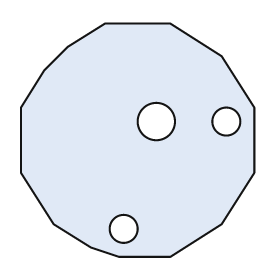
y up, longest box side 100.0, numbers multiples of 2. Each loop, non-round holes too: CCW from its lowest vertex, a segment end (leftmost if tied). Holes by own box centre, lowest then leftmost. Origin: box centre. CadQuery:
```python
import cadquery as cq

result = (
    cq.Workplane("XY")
    .moveTo(-8.0, -50.0)
    .lineTo(14.0, -50.0)
    .lineTo(36.0, -36.0)
    .lineTo(50.0, -14.0)
    .lineTo(50.0, 14.0)
    .lineTo(36.0, 36.0)
    .lineTo(14.0, 50.0)
    .lineTo(-14.0, 50.0)
    .lineTo(-30.0, 40.0)
    .lineTo(-40.0, 30.0)
    .lineTo(-50.0, 14.0)
    .lineTo(-50.0, -14.0)
    .lineTo(-36.0, -36.0)
    .lineTo(-20.0, -46.0)
    .close()
    .moveTo(-6.0, -38.0)
    .circle(6.0)
    .moveTo(8.0, 8.0)
    .circle(8.0)
    .moveTo(38.0, 8.0)
    .circle(6.0)
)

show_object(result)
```